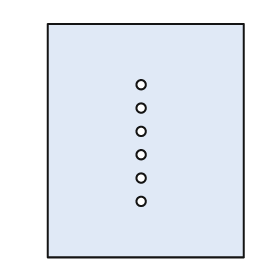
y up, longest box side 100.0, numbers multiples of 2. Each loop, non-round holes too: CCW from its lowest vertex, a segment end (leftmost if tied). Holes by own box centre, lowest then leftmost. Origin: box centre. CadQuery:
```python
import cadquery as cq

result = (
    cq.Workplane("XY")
    .moveTo(-42.0, -50.0)
    .lineTo(42.0, -50.0)
    .lineTo(42.0, 50.0)
    .lineTo(-42.0, 50.0)
    .close()
    .moveTo(-2.0, -26.0)
    .circle(2.0)
    .moveTo(-2.0, -16.0)
    .circle(2.0)
    .moveTo(-2.0, -6.0)
    .circle(2.0)
    .moveTo(-2.0, 4.0)
    .circle(2.0)
    .moveTo(-2.0, 14.0)
    .circle(2.0)
    .moveTo(-2.0, 24.0)
    .circle(2.0)
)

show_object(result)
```